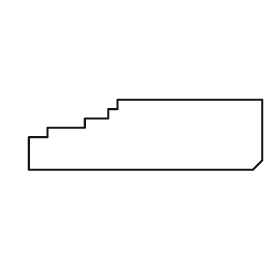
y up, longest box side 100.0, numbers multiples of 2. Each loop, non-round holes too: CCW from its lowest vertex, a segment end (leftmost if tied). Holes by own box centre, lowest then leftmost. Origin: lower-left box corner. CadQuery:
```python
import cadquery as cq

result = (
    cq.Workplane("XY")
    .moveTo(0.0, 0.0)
    .lineTo(96.0, 0.0)
    .lineTo(100.0, 4.0)
    .lineTo(100.0, 30.0)
    .lineTo(38.0, 30.0)
    .lineTo(38.0, 26.0)
    .lineTo(34.0, 26.0)
    .lineTo(34.0, 22.0)
    .lineTo(24.0, 22.0)
    .lineTo(24.0, 18.0)
    .lineTo(8.0, 18.0)
    .lineTo(8.0, 14.0)
    .lineTo(0.0, 14.0)
    .close()
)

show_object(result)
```